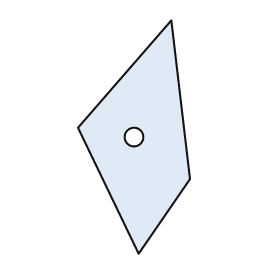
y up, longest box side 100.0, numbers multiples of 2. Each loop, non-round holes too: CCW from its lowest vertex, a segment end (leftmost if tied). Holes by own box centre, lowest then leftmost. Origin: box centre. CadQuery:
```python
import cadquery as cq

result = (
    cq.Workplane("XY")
    .moveTo(2.0, -50.0)
    .lineTo(24.0, -18.0)
    .lineTo(16.0, 50.0)
    .lineTo(-24.0, 4.0)
    .close()
    .moveTo(0.0, 0.0)
    .circle(4.0)
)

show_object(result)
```